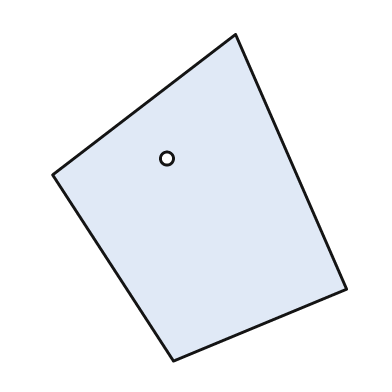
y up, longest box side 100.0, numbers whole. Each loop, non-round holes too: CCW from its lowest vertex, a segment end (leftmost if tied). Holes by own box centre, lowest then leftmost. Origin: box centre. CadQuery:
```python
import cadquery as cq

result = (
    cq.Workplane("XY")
    .moveTo(-8.0, -50.0)
    .lineTo(45.0, -28.0)
    .lineTo(11.0, 50.0)
    .lineTo(-45.0, 7.0)
    .close()
    .moveTo(-10.0, 12.0)
    .circle(2.0)
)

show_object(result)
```